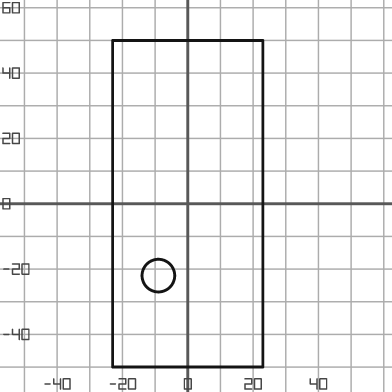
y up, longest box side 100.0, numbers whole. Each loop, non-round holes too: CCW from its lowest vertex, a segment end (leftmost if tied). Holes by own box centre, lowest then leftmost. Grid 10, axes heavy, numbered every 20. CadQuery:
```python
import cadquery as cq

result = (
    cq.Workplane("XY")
    .moveTo(-23.0, -50.0)
    .lineTo(23.0, -50.0)
    .lineTo(23.0, 50.0)
    .lineTo(-23.0, 50.0)
    .close()
    .moveTo(-9.0, -22.0)
    .circle(5.0)
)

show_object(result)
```